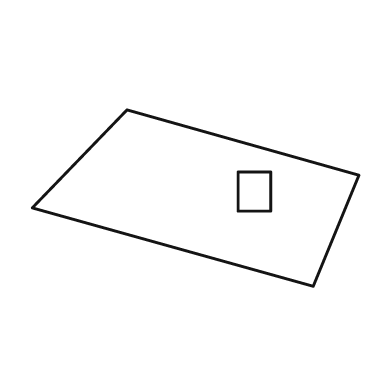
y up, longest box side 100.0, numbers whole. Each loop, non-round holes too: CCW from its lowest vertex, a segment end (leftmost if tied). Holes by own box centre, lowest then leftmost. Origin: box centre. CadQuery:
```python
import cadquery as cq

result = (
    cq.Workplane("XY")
    .moveTo(36.0, -27.0)
    .lineTo(50.0, 7.0)
    .lineTo(-21.0, 27.0)
    .lineTo(-50.0, -3.0)
    .close()
    .moveTo(13.0, -4.0)
    .lineTo(23.0, -4.0)
    .lineTo(23.0, 8.0)
    .lineTo(13.0, 8.0)
    .close()
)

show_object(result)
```